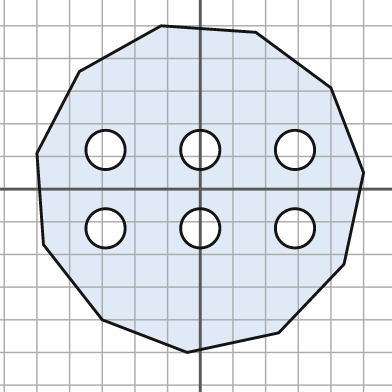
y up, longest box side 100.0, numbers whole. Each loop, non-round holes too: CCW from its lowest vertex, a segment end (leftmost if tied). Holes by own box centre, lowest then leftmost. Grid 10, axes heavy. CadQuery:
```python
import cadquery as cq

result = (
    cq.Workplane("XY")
    .moveTo(-4.0, -50.0)
    .lineTo(24.0, -44.0)
    .lineTo(44.0, -23.0)
    .lineTo(50.0, 5.0)
    .lineTo(40.0, 31.0)
    .lineTo(17.0, 48.0)
    .lineTo(-12.0, 50.0)
    .lineTo(-37.0, 36.0)
    .lineTo(-50.0, 11.0)
    .lineTo(-48.0, -17.0)
    .lineTo(-30.0, -40.0)
    .close()
    .moveTo(-29.0, -12.0)
    .circle(6.0)
    .moveTo(0.0, -12.0)
    .circle(6.0)
    .moveTo(29.0, -12.0)
    .circle(6.0)
    .moveTo(-29.0, 12.0)
    .circle(6.0)
    .moveTo(0.0, 12.0)
    .circle(6.0)
    .moveTo(29.0, 12.0)
    .circle(6.0)
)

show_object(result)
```